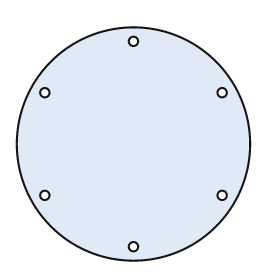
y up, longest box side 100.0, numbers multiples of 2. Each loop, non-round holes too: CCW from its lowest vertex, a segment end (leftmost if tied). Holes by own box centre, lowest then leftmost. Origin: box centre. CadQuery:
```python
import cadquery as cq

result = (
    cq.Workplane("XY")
    .moveTo(0.0, 0.0)
    .circle(50.0)
    .moveTo(0.0, -44.0)
    .circle(2.0)
    .moveTo(-38.0, -22.0)
    .circle(2.0)
    .moveTo(38.0, -22.0)
    .circle(2.0)
    .moveTo(-38.0, 22.0)
    .circle(2.0)
    .moveTo(38.0, 22.0)
    .circle(2.0)
    .moveTo(0.0, 44.0)
    .circle(2.0)
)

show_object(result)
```